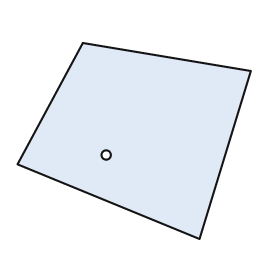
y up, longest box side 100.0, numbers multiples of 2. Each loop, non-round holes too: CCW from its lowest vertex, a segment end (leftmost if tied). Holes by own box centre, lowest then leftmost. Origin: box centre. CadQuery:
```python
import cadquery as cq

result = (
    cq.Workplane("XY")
    .moveTo(28.0, -42.0)
    .lineTo(50.0, 30.0)
    .lineTo(-22.0, 42.0)
    .lineTo(-50.0, -10.0)
    .close()
    .moveTo(-12.0, -6.0)
    .circle(2.0)
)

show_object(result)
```